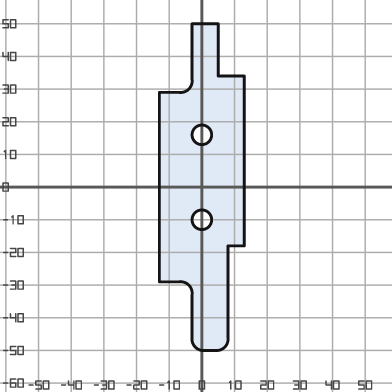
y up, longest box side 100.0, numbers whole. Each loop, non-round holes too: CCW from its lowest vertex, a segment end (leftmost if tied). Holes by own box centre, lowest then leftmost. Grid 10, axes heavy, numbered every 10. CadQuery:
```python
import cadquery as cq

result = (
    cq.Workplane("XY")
    .moveTo(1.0, -50.0)
    .lineTo(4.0, -50.0)
    .threePointArc((7.0, -49.0), (8.0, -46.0))
    .lineTo(8.0, -18.0)
    .lineTo(13.0, -18.0)
    .lineTo(13.0, 34.0)
    .lineTo(5.0, 34.0)
    .lineTo(5.0, 50.0)
    .lineTo(-3.0, 50.0)
    .lineTo(-3.0, 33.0)
    .threePointArc((-4.0, 30.0), (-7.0, 29.0))
    .lineTo(-13.0, 29.0)
    .lineTo(-13.0, -29.0)
    .lineTo(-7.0, -29.0)
    .threePointArc((-4.0, -30.0), (-3.0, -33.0))
    .lineTo(-3.0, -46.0)
    .threePointArc((-2.0, -49.0), (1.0, -50.0))
    .close()
    .moveTo(0.0, -10.0)
    .circle(3.0)
    .moveTo(0.0, 16.0)
    .circle(3.0)
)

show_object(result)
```